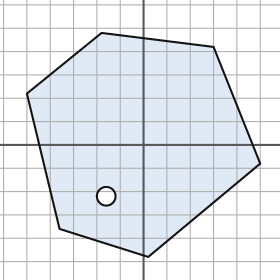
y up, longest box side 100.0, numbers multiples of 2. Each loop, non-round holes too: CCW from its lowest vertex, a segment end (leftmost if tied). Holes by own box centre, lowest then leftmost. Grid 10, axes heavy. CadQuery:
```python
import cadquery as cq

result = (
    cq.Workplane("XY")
    .moveTo(2.0, -48.0)
    .lineTo(50.0, -8.0)
    .lineTo(30.0, 42.0)
    .lineTo(-18.0, 48.0)
    .lineTo(-50.0, 22.0)
    .lineTo(-36.0, -36.0)
    .close()
    .moveTo(-16.0, -22.0)
    .circle(4.0)
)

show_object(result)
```